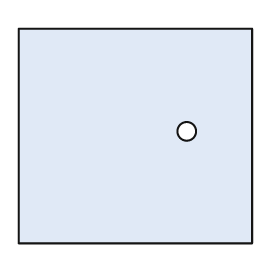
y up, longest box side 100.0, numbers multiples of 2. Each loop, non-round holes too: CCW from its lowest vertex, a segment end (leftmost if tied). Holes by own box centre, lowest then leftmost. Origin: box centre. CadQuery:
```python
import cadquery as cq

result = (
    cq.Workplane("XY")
    .moveTo(-50.0, -46.0)
    .lineTo(50.0, -46.0)
    .lineTo(50.0, 46.0)
    .lineTo(-50.0, 46.0)
    .close()
    .moveTo(22.0, 2.0)
    .circle(4.0)
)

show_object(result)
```